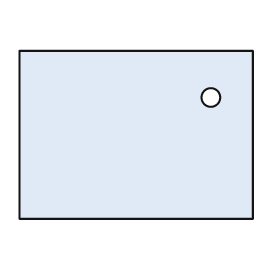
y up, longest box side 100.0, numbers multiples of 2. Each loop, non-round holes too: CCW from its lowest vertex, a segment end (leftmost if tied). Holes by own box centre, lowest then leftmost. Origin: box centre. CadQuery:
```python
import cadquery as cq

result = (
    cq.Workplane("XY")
    .moveTo(-50.0, -36.0)
    .lineTo(50.0, -36.0)
    .lineTo(50.0, 36.0)
    .lineTo(-50.0, 36.0)
    .close()
    .moveTo(32.0, 16.0)
    .circle(4.0)
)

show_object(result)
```